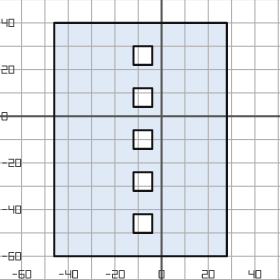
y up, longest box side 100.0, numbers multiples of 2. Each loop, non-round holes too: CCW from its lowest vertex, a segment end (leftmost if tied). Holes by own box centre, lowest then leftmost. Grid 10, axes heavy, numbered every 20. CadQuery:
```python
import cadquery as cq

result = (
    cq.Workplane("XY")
    .moveTo(-46.0, -60.0)
    .lineTo(28.0, -60.0)
    .lineTo(28.0, 40.0)
    .lineTo(-46.0, 40.0)
    .close()
    .moveTo(-12.0, -50.0)
    .lineTo(-4.0, -50.0)
    .lineTo(-4.0, -42.0)
    .lineTo(-12.0, -42.0)
    .close()
    .moveTo(-12.0, -32.0)
    .lineTo(-4.0, -32.0)
    .lineTo(-4.0, -24.0)
    .lineTo(-12.0, -24.0)
    .close()
    .moveTo(-12.0, -14.0)
    .lineTo(-4.0, -14.0)
    .lineTo(-4.0, -6.0)
    .lineTo(-12.0, -6.0)
    .close()
    .moveTo(-12.0, 4.0)
    .lineTo(-4.0, 4.0)
    .lineTo(-4.0, 12.0)
    .lineTo(-12.0, 12.0)
    .close()
    .moveTo(-12.0, 22.0)
    .lineTo(-4.0, 22.0)
    .lineTo(-4.0, 30.0)
    .lineTo(-12.0, 30.0)
    .close()
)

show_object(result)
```